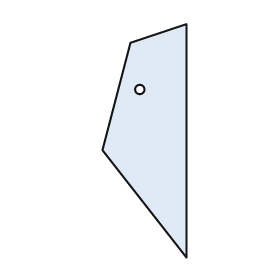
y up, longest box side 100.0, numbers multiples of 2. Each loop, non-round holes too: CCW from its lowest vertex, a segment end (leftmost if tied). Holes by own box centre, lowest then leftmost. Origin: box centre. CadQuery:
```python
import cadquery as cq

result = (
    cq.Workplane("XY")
    .moveTo(18.0, -50.0)
    .lineTo(18.0, 50.0)
    .lineTo(-6.0, 42.0)
    .lineTo(-18.0, -4.0)
    .close()
    .moveTo(-2.0, 22.0)
    .circle(2.0)
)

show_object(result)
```